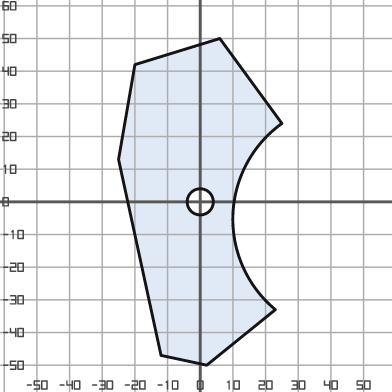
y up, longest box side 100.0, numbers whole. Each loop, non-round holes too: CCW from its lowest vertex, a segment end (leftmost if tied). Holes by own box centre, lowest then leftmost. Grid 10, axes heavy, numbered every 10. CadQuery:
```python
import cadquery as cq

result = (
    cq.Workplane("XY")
    .moveTo(2.0, -50.0)
    .lineTo(23.0, -33.0)
    .threePointArc((10.0, -4.0), (25.0, 24.0))
    .lineTo(6.0, 50.0)
    .lineTo(-20.0, 42.0)
    .lineTo(-25.0, 13.0)
    .lineTo(-12.0, -47.0)
    .close()
    .moveTo(0.0, 0.0)
    .circle(4.0)
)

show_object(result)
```